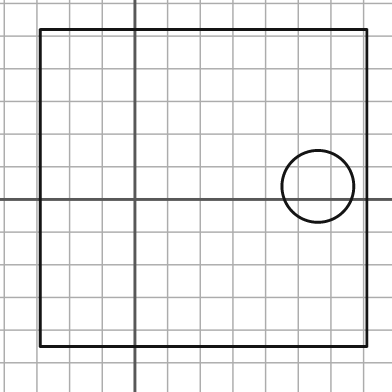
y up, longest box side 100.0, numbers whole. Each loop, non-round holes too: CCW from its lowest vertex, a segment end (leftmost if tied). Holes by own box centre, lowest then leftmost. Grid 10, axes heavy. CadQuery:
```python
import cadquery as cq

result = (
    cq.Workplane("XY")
    .moveTo(-29.0, -45.0)
    .lineTo(71.0, -45.0)
    .lineTo(71.0, 52.0)
    .lineTo(-29.0, 52.0)
    .close()
    .moveTo(56.0, 4.0)
    .circle(11.0)
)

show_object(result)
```